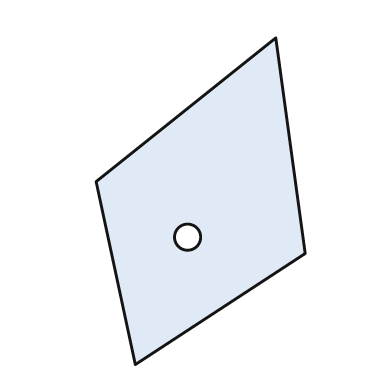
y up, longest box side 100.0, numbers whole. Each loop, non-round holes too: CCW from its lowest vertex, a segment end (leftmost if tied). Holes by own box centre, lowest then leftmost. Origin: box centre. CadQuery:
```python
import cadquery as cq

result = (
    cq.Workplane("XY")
    .moveTo(-20.0, -50.0)
    .lineTo(32.0, -16.0)
    .lineTo(23.0, 50.0)
    .lineTo(-32.0, 6.0)
    .close()
    .moveTo(-4.0, -11.0)
    .circle(4.0)
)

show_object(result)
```